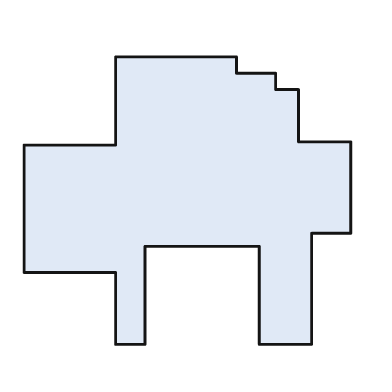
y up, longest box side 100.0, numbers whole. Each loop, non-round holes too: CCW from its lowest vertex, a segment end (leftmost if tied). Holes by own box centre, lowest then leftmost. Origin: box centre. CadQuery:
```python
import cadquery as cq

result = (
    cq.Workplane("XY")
    .moveTo(-22.0, -44.0)
    .lineTo(-13.0, -44.0)
    .lineTo(-13.0, -14.0)
    .lineTo(22.0, -14.0)
    .lineTo(22.0, -44.0)
    .lineTo(38.0, -44.0)
    .lineTo(38.0, -10.0)
    .lineTo(50.0, -10.0)
    .lineTo(50.0, 18.0)
    .lineTo(34.0, 18.0)
    .lineTo(34.0, 34.0)
    .lineTo(27.0, 34.0)
    .lineTo(27.0, 39.0)
    .lineTo(15.0, 39.0)
    .lineTo(15.0, 44.0)
    .lineTo(-22.0, 44.0)
    .lineTo(-22.0, 17.0)
    .lineTo(-50.0, 17.0)
    .lineTo(-50.0, -22.0)
    .lineTo(-22.0, -22.0)
    .close()
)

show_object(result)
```